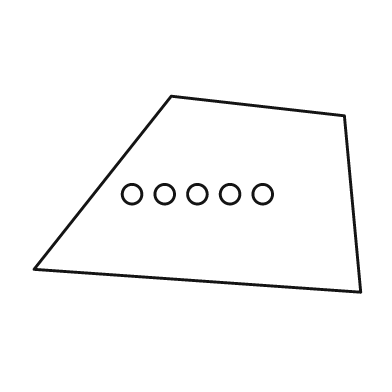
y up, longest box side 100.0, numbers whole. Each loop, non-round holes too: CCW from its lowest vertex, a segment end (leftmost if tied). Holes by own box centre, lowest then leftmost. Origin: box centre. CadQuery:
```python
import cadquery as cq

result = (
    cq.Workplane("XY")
    .moveTo(50.0, -30.0)
    .lineTo(45.0, 24.0)
    .lineTo(-8.0, 30.0)
    .lineTo(-50.0, -23.0)
    .close()
    .moveTo(-20.0, 0.0)
    .circle(3.0)
    .moveTo(-10.0, 0.0)
    .circle(3.0)
    .moveTo(0.0, 0.0)
    .circle(3.0)
    .moveTo(10.0, 0.0)
    .circle(3.0)
    .moveTo(20.0, 0.0)
    .circle(3.0)
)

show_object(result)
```